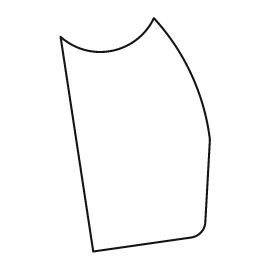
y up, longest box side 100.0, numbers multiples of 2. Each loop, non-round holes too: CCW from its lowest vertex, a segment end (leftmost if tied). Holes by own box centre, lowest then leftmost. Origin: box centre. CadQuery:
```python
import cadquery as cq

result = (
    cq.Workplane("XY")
    .moveTo(-18.0, -50.0)
    .lineTo(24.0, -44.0)
    .threePointArc((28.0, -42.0), (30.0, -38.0))
    .lineTo(32.0, -2.0)
    .threePointArc((24.0, 26.0), (8.0, 50.0))
    .threePointArc((-10.0, 36.0), (-32.0, 42.0))
    .close()
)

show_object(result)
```